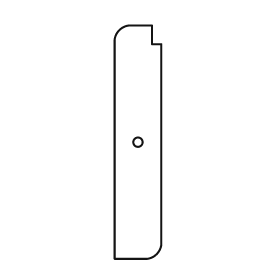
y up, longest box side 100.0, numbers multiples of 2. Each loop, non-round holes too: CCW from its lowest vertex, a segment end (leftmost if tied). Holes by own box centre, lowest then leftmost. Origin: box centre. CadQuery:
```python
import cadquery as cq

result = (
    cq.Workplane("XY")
    .moveTo(-10.0, -50.0)
    .lineTo(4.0, -50.0)
    .threePointArc((8.0, -48.0), (10.0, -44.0))
    .lineTo(10.0, 42.0)
    .lineTo(6.0, 42.0)
    .lineTo(6.0, 50.0)
    .lineTo(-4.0, 50.0)
    .threePointArc((-8.0, 48.0), (-10.0, 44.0))
    .close()
    .moveTo(0.0, 0.0)
    .circle(2.0)
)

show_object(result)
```